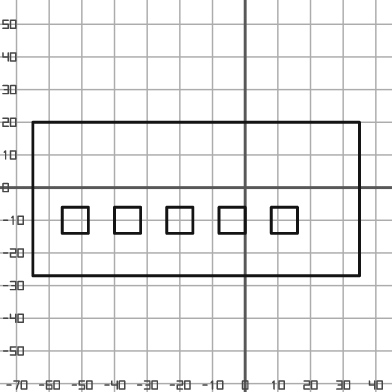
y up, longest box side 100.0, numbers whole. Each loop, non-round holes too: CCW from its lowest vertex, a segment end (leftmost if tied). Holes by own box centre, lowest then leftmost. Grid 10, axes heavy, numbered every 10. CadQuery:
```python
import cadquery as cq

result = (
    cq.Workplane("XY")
    .moveTo(-65.0, -27.0)
    .lineTo(35.0, -27.0)
    .lineTo(35.0, 20.0)
    .lineTo(-65.0, 20.0)
    .close()
    .moveTo(-56.0, -14.0)
    .lineTo(-48.0, -14.0)
    .lineTo(-48.0, -6.0)
    .lineTo(-56.0, -6.0)
    .close()
    .moveTo(-40.0, -14.0)
    .lineTo(-32.0, -14.0)
    .lineTo(-32.0, -6.0)
    .lineTo(-40.0, -6.0)
    .close()
    .moveTo(-24.0, -14.0)
    .lineTo(-16.0, -14.0)
    .lineTo(-16.0, -6.0)
    .lineTo(-24.0, -6.0)
    .close()
    .moveTo(-8.0, -14.0)
    .lineTo(0.0, -14.0)
    .lineTo(0.0, -6.0)
    .lineTo(-8.0, -6.0)
    .close()
    .moveTo(8.0, -14.0)
    .lineTo(16.0, -14.0)
    .lineTo(16.0, -6.0)
    .lineTo(8.0, -6.0)
    .close()
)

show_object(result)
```